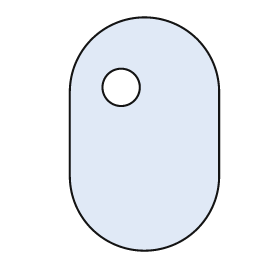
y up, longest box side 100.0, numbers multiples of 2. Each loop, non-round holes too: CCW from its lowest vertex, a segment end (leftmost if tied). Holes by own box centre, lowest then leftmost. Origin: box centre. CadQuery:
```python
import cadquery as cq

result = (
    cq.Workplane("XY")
    .moveTo(-32.0, -18.0)
    .threePointArc((0.0, -50.0), (32.0, -18.0))
    .lineTo(32.0, 18.0)
    .threePointArc((0.0, 50.0), (-32.0, 18.0))
    .close()
    .moveTo(-10.0, 20.0)
    .circle(8.0)
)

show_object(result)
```